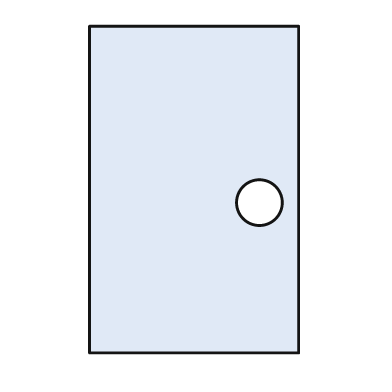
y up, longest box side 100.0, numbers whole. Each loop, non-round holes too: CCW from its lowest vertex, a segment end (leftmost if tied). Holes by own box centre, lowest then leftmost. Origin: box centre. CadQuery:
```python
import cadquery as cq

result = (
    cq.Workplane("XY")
    .moveTo(-32.0, -50.0)
    .lineTo(32.0, -50.0)
    .lineTo(32.0, 50.0)
    .lineTo(-32.0, 50.0)
    .close()
    .moveTo(20.0, -4.0)
    .circle(7.0)
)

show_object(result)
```